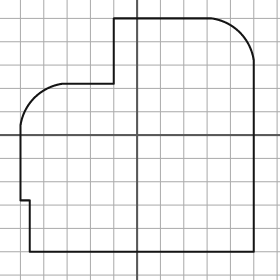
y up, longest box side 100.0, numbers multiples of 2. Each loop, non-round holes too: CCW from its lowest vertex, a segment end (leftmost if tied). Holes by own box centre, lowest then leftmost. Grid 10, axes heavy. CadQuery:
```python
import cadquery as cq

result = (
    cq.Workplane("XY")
    .moveTo(-46.0, -50.0)
    .lineTo(50.0, -50.0)
    .lineTo(50.0, 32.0)
    .threePointArc((44.0, 44.0), (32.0, 50.0))
    .lineTo(-10.0, 50.0)
    .lineTo(-10.0, 22.0)
    .lineTo(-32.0, 22.0)
    .threePointArc((-44.0, 16.0), (-50.0, 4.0))
    .lineTo(-50.0, -28.0)
    .lineTo(-46.0, -28.0)
    .close()
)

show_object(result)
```